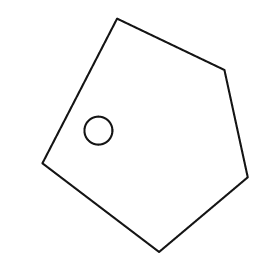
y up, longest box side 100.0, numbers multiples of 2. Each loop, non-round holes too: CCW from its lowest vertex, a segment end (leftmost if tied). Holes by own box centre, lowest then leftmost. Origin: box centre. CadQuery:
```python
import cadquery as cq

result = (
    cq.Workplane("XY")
    .moveTo(6.0, -50.0)
    .lineTo(44.0, -18.0)
    .lineTo(34.0, 28.0)
    .lineTo(-12.0, 50.0)
    .lineTo(-44.0, -12.0)
    .close()
    .moveTo(-20.0, 2.0)
    .circle(6.0)
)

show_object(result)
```